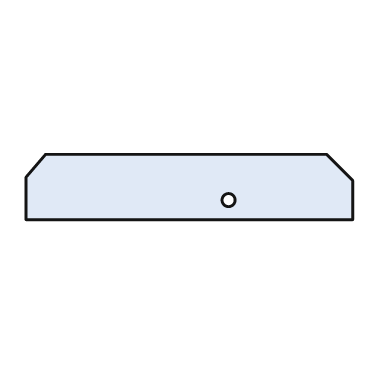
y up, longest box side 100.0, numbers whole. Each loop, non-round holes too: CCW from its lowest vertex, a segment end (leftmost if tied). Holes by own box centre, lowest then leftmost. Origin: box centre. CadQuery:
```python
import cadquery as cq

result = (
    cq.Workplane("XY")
    .moveTo(-50.0, -10.0)
    .lineTo(50.0, -10.0)
    .lineTo(50.0, 2.0)
    .lineTo(42.0, 10.0)
    .lineTo(-44.0, 10.0)
    .lineTo(-50.0, 3.0)
    .close()
    .moveTo(12.0, -4.0)
    .circle(2.0)
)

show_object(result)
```